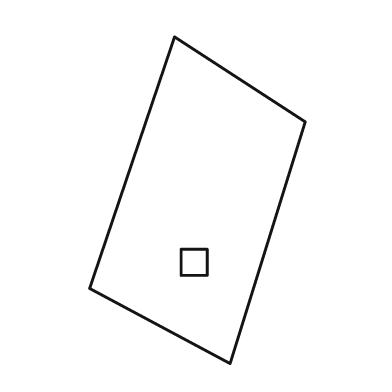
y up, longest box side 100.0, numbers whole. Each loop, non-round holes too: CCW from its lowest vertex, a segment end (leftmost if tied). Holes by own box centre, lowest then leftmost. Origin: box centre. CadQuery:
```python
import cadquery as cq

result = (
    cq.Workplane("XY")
    .moveTo(10.0, -50.0)
    .lineTo(33.0, 24.0)
    .lineTo(-7.0, 50.0)
    .lineTo(-33.0, -27.0)
    .close()
    .moveTo(-5.0, -23.0)
    .lineTo(3.0, -23.0)
    .lineTo(3.0, -15.0)
    .lineTo(-5.0, -15.0)
    .close()
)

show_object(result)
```